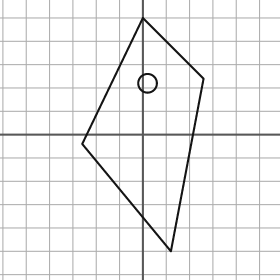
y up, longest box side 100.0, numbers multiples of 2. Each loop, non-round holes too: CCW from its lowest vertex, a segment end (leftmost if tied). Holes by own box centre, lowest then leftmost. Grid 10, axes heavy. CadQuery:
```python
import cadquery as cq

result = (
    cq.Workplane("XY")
    .moveTo(12.0, -50.0)
    .lineTo(26.0, 24.0)
    .lineTo(0.0, 50.0)
    .lineTo(-26.0, -4.0)
    .close()
    .moveTo(2.0, 22.0)
    .circle(4.0)
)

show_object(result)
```